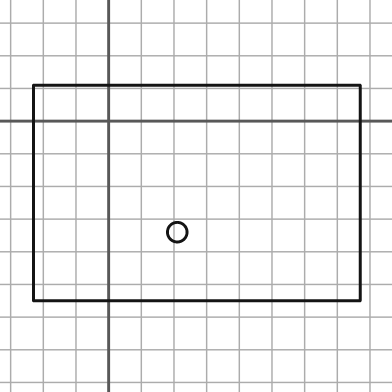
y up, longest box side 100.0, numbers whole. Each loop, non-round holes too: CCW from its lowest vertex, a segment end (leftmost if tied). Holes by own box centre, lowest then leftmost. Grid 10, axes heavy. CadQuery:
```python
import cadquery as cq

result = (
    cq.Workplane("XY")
    .moveTo(-23.0, -55.0)
    .lineTo(77.0, -55.0)
    .lineTo(77.0, 11.0)
    .lineTo(-23.0, 11.0)
    .close()
    .moveTo(21.0, -34.0)
    .circle(3.0)
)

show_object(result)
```